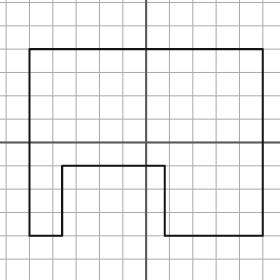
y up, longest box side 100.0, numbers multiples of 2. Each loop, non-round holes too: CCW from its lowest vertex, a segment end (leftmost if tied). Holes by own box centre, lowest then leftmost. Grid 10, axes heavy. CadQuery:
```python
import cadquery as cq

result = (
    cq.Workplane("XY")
    .moveTo(-50.0, -40.0)
    .lineTo(-36.0, -40.0)
    .lineTo(-36.0, -10.0)
    .lineTo(8.0, -10.0)
    .lineTo(8.0, -40.0)
    .lineTo(50.0, -40.0)
    .lineTo(50.0, 40.0)
    .lineTo(-50.0, 40.0)
    .close()
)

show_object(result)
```